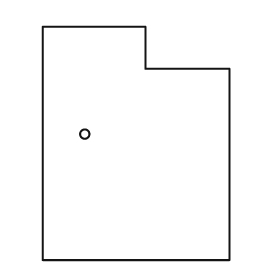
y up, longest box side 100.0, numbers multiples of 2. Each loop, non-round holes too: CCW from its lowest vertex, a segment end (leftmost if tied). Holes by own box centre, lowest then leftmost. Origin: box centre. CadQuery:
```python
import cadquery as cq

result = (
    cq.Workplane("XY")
    .moveTo(-40.0, -50.0)
    .lineTo(40.0, -50.0)
    .lineTo(40.0, 32.0)
    .lineTo(4.0, 32.0)
    .lineTo(4.0, 50.0)
    .lineTo(-40.0, 50.0)
    .close()
    .moveTo(-22.0, 4.0)
    .circle(2.0)
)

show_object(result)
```